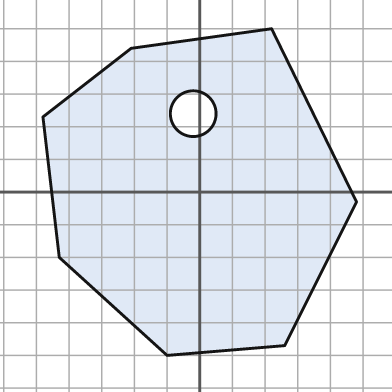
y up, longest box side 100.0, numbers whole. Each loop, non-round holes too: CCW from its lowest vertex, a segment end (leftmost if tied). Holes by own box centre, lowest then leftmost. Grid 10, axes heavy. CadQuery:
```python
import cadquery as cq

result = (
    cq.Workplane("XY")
    .moveTo(-10.0, -50.0)
    .lineTo(26.0, -47.0)
    .lineTo(48.0, -3.0)
    .lineTo(22.0, 50.0)
    .lineTo(-21.0, 44.0)
    .lineTo(-48.0, 23.0)
    .lineTo(-43.0, -20.0)
    .close()
    .moveTo(-2.0, 24.0)
    .circle(7.0)
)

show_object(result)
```